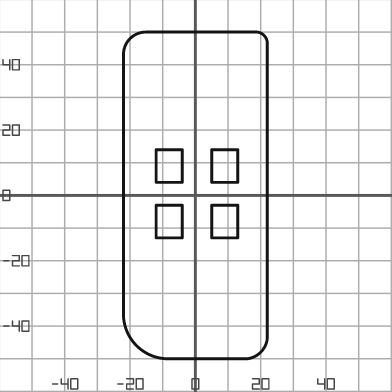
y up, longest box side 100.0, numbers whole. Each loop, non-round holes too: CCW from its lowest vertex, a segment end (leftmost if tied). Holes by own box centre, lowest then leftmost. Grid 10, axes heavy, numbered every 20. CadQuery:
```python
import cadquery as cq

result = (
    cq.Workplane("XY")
    .moveTo(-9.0, -50.0)
    .lineTo(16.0, -50.0)
    .threePointArc((20.0, -48.0), (22.0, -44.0))
    .lineTo(22.0, 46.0)
    .threePointArc((21.0, 49.0), (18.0, 50.0))
    .lineTo(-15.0, 50.0)
    .threePointArc((-20.0, 48.0), (-22.0, 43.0))
    .lineTo(-22.0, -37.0)
    .threePointArc((-18.0, -46.0), (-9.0, -50.0))
    .close()
    .moveTo(-12.0, -13.0)
    .lineTo(-4.0, -13.0)
    .lineTo(-4.0, -3.0)
    .lineTo(-12.0, -3.0)
    .close()
    .moveTo(5.0, -13.0)
    .lineTo(13.0, -13.0)
    .lineTo(13.0, -3.0)
    .lineTo(5.0, -3.0)
    .close()
    .moveTo(-12.0, 4.0)
    .lineTo(-4.0, 4.0)
    .lineTo(-4.0, 14.0)
    .lineTo(-12.0, 14.0)
    .close()
    .moveTo(5.0, 4.0)
    .lineTo(13.0, 4.0)
    .lineTo(13.0, 14.0)
    .lineTo(5.0, 14.0)
    .close()
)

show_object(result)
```